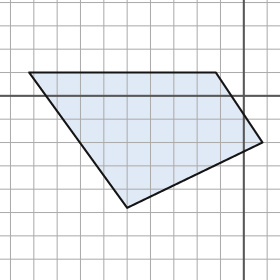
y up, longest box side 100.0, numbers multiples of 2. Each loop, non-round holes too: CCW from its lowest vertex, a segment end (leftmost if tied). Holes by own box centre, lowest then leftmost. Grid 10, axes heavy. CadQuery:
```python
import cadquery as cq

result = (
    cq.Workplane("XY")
    .moveTo(-50.0, -48.0)
    .lineTo(8.0, -20.0)
    .lineTo(-12.0, 10.0)
    .lineTo(-92.0, 10.0)
    .close()
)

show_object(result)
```